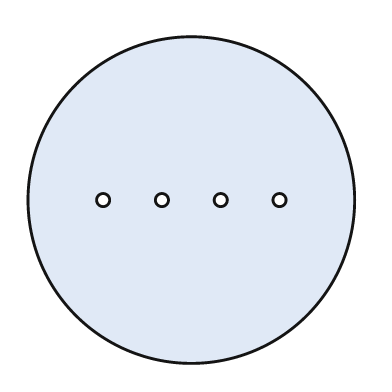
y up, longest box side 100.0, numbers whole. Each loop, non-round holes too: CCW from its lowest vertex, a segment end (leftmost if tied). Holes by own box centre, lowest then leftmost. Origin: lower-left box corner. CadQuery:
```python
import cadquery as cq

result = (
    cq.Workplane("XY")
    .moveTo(50.0, 50.0)
    .circle(50.0)
    .moveTo(23.0, 50.0)
    .circle(2.0)
    .moveTo(41.0, 50.0)
    .circle(2.0)
    .moveTo(59.0, 50.0)
    .circle(2.0)
    .moveTo(77.0, 50.0)
    .circle(2.0)
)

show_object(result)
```